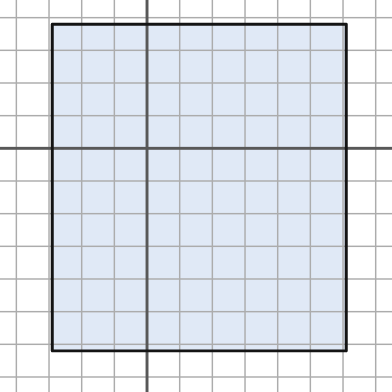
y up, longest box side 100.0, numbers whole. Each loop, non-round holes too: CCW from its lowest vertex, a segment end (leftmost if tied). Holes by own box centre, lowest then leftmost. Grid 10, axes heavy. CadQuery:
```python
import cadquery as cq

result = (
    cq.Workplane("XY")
    .moveTo(-29.0, -62.0)
    .lineTo(61.0, -62.0)
    .lineTo(61.0, 38.0)
    .lineTo(-29.0, 38.0)
    .close()
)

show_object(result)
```